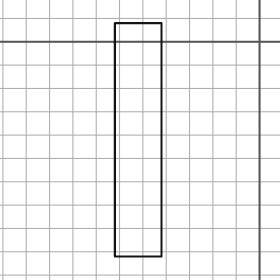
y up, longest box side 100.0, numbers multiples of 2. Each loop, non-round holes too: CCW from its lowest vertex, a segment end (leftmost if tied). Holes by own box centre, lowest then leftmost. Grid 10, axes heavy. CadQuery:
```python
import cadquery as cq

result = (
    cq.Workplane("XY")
    .moveTo(-62.0, -92.0)
    .lineTo(-42.0, -92.0)
    .lineTo(-42.0, 8.0)
    .lineTo(-62.0, 8.0)
    .close()
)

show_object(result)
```